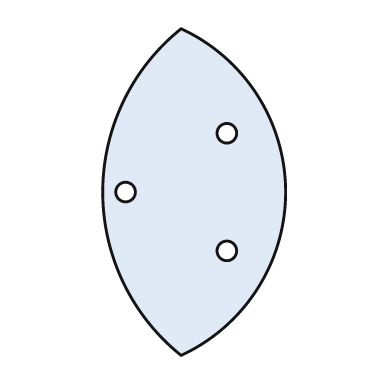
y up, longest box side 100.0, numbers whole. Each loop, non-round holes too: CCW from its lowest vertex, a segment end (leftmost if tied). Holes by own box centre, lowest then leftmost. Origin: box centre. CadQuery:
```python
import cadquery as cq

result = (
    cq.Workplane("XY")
    .moveTo(-4.0, -50.0)
    .threePointArc((28.0, 0.0), (-4.0, 50.0))
    .threePointArc((-28.0, 0.0), (-4.0, -50.0))
    .close()
    .moveTo(10.0, -18.0)
    .circle(3.0)
    .moveTo(-21.0, 0.0)
    .circle(3.0)
    .moveTo(10.0, 18.0)
    .circle(3.0)
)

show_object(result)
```